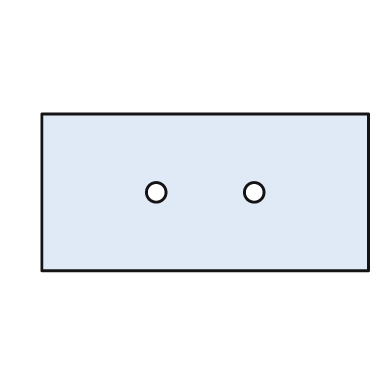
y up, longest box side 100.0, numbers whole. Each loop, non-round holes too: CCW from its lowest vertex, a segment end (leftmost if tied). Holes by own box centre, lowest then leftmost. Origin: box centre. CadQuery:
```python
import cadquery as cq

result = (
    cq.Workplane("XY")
    .moveTo(-50.0, -24.0)
    .lineTo(50.0, -24.0)
    .lineTo(50.0, 24.0)
    .lineTo(-50.0, 24.0)
    .close()
    .moveTo(-15.0, 0.0)
    .circle(3.0)
    .moveTo(15.0, 0.0)
    .circle(3.0)
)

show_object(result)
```